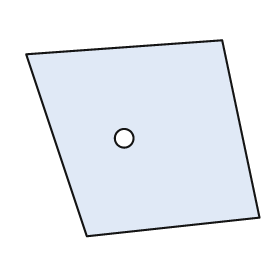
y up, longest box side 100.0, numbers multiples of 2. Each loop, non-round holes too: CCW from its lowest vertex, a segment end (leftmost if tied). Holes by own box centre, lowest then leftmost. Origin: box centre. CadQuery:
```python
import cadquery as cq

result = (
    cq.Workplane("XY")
    .moveTo(-24.0, -42.0)
    .lineTo(50.0, -34.0)
    .lineTo(34.0, 42.0)
    .lineTo(-50.0, 36.0)
    .close()
    .moveTo(-8.0, 0.0)
    .circle(4.0)
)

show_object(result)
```